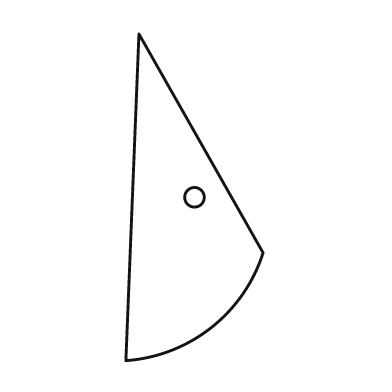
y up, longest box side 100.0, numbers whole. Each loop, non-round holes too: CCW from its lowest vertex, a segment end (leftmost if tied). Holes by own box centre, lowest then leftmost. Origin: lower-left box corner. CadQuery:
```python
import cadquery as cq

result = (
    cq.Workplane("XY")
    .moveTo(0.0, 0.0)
    .threePointArc((26.0, 10.0), (42.0, 33.0))
    .lineTo(4.0, 100.0)
    .close()
    .moveTo(21.0, 50.0)
    .circle(3.0)
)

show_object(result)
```